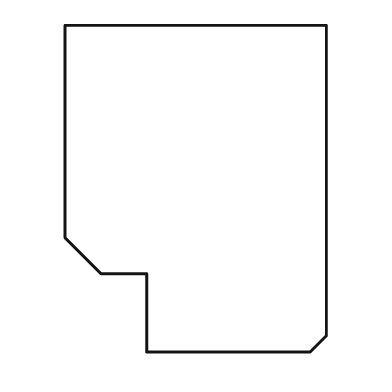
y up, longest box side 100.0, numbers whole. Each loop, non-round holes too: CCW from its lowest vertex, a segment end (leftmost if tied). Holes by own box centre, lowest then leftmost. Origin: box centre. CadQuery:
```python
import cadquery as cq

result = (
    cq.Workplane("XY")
    .moveTo(-15.0, -50.0)
    .lineTo(35.0, -50.0)
    .lineTo(40.0, -45.0)
    .lineTo(40.0, 50.0)
    .lineTo(-40.0, 50.0)
    .lineTo(-40.0, -15.0)
    .lineTo(-29.0, -26.0)
    .lineTo(-15.0, -26.0)
    .close()
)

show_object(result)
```